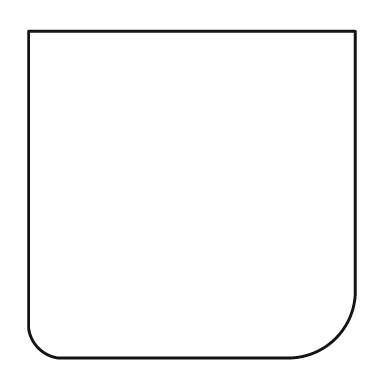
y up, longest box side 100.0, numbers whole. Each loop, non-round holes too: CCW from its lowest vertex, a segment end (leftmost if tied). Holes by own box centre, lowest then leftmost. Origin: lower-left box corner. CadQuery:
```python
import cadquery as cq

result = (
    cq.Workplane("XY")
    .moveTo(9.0, 0.0)
    .lineTo(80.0, 0.0)
    .threePointArc((94.0, 6.0), (100.0, 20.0))
    .lineTo(100.0, 100.0)
    .lineTo(0.0, 100.0)
    .lineTo(0.0, 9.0)
    .threePointArc((3.0, 3.0), (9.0, 0.0))
    .close()
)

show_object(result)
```